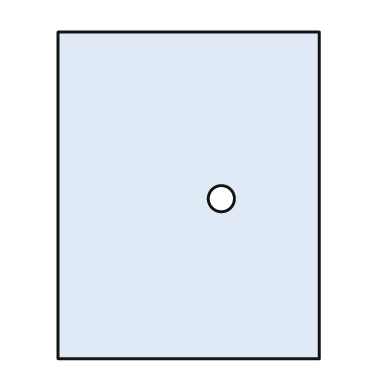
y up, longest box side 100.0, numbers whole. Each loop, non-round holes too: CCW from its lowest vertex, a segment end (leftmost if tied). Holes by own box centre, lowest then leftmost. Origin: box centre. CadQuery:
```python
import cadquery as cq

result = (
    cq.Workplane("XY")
    .moveTo(-40.0, -50.0)
    .lineTo(40.0, -50.0)
    .lineTo(40.0, 50.0)
    .lineTo(-40.0, 50.0)
    .close()
    .moveTo(10.0, -1.0)
    .circle(4.0)
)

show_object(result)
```